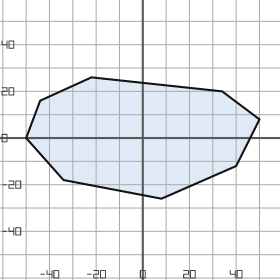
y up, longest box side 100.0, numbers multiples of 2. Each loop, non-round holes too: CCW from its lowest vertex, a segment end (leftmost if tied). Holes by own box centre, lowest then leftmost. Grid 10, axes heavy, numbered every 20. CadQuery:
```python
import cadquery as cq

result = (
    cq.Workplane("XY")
    .moveTo(8.0, -26.0)
    .lineTo(40.0, -12.0)
    .lineTo(50.0, 8.0)
    .lineTo(34.0, 20.0)
    .lineTo(-22.0, 26.0)
    .lineTo(-44.0, 16.0)
    .lineTo(-50.0, 0.0)
    .lineTo(-34.0, -18.0)
    .close()
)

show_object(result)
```